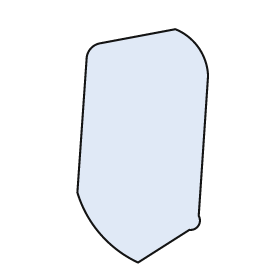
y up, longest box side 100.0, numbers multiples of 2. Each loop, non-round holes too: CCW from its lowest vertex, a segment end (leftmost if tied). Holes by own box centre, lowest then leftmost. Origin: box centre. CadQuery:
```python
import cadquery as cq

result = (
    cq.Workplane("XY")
    .moveTo(-2.0, -50.0)
    .lineTo(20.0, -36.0)
    .threePointArc((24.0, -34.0), (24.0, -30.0))
    .lineTo(28.0, 30.0)
    .threePointArc((24.0, 42.0), (14.0, 50.0))
    .lineTo(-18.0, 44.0)
    .threePointArc((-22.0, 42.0), (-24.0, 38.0))
    .lineTo(-28.0, -20.0)
    .threePointArc((-18.0, -38.0), (-2.0, -50.0))
    .close()
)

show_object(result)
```